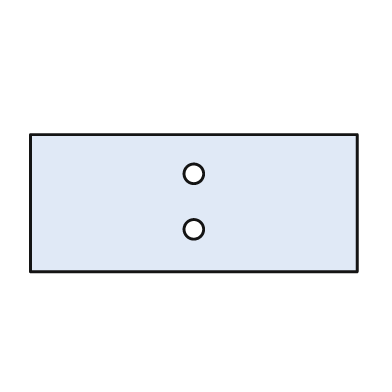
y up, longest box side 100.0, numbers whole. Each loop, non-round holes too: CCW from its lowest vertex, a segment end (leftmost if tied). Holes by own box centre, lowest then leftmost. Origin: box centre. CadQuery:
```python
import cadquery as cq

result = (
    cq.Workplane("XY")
    .moveTo(-50.0, -21.0)
    .lineTo(50.0, -21.0)
    .lineTo(50.0, 21.0)
    .lineTo(-50.0, 21.0)
    .close()
    .moveTo(0.0, -8.0)
    .circle(3.0)
    .moveTo(0.0, 9.0)
    .circle(3.0)
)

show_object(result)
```